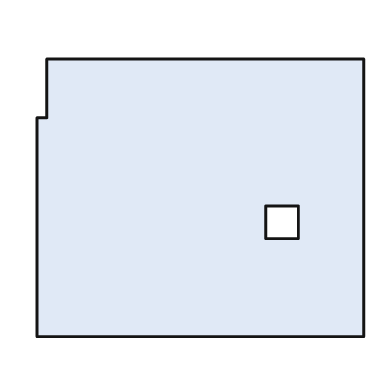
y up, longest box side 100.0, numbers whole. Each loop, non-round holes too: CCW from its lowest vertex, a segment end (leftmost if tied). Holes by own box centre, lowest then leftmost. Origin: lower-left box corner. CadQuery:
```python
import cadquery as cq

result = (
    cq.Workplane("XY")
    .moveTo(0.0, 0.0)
    .lineTo(100.0, 0.0)
    .lineTo(100.0, 85.0)
    .lineTo(3.0, 85.0)
    .lineTo(3.0, 67.0)
    .lineTo(0.0, 67.0)
    .close()
    .moveTo(70.0, 30.0)
    .lineTo(80.0, 30.0)
    .lineTo(80.0, 40.0)
    .lineTo(70.0, 40.0)
    .close()
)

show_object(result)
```